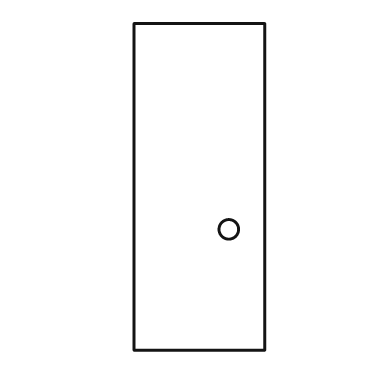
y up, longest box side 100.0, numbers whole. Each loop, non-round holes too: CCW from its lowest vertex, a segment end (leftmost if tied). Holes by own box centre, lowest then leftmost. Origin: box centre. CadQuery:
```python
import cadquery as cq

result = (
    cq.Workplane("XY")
    .moveTo(-20.0, -50.0)
    .lineTo(20.0, -50.0)
    .lineTo(20.0, 50.0)
    .lineTo(-20.0, 50.0)
    .close()
    .moveTo(9.0, -13.0)
    .circle(3.0)
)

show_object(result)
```